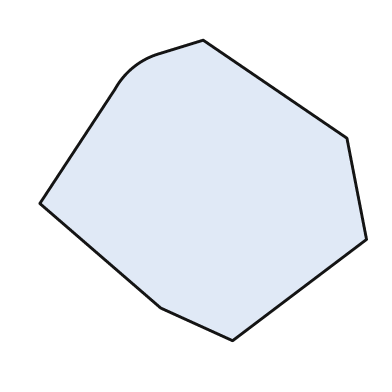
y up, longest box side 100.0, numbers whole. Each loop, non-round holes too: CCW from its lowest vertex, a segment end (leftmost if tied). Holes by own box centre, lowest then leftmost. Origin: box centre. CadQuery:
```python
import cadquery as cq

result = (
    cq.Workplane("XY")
    .moveTo(9.0, -46.0)
    .lineTo(50.0, -15.0)
    .lineTo(44.0, 16.0)
    .lineTo(0.0, 46.0)
    .lineTo(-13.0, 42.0)
    .threePointArc((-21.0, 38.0), (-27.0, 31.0))
    .lineTo(-50.0, -4.0)
    .lineTo(-13.0, -36.0)
    .close()
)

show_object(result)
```